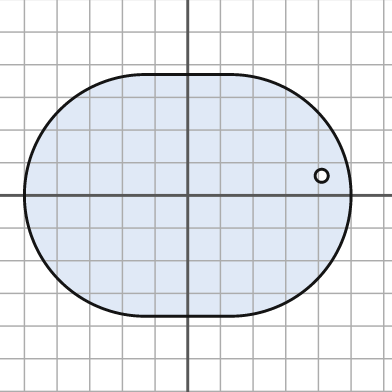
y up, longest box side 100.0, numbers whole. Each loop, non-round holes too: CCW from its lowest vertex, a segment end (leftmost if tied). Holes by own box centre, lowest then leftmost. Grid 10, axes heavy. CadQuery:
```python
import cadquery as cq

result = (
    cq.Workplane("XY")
    .moveTo(-13.0, -37.0)
    .lineTo(13.0, -37.0)
    .threePointArc((50.0, 0.0), (13.0, 37.0))
    .lineTo(-13.0, 37.0)
    .threePointArc((-50.0, 0.0), (-13.0, -37.0))
    .close()
    .moveTo(41.0, 6.0)
    .circle(2.0)
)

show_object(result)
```